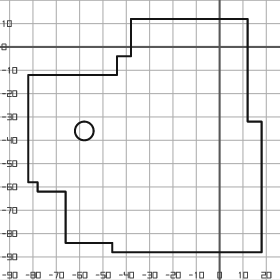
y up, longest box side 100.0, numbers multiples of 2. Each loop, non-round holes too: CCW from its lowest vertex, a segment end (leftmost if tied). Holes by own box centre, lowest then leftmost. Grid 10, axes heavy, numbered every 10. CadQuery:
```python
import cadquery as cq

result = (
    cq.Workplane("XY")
    .moveTo(-46.0, -88.0)
    .lineTo(18.0, -88.0)
    .lineTo(18.0, -32.0)
    .lineTo(12.0, -32.0)
    .lineTo(12.0, 12.0)
    .lineTo(-38.0, 12.0)
    .lineTo(-38.0, -4.0)
    .lineTo(-44.0, -4.0)
    .lineTo(-44.0, -12.0)
    .lineTo(-82.0, -12.0)
    .lineTo(-82.0, -58.0)
    .lineTo(-78.0, -58.0)
    .lineTo(-78.0, -62.0)
    .lineTo(-66.0, -62.0)
    .lineTo(-66.0, -84.0)
    .lineTo(-46.0, -84.0)
    .close()
    .moveTo(-58.0, -36.0)
    .circle(4.0)
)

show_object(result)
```